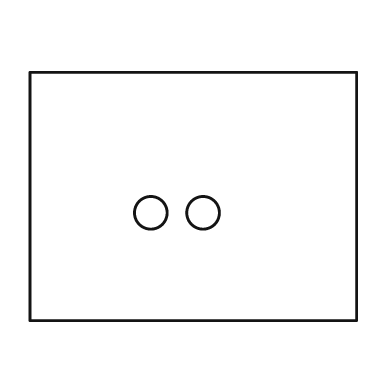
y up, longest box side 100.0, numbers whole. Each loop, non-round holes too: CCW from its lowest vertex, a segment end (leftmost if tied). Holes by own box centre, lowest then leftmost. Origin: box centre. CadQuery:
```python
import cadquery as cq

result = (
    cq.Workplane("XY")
    .moveTo(-50.0, -38.0)
    .lineTo(50.0, -38.0)
    .lineTo(50.0, 38.0)
    .lineTo(-50.0, 38.0)
    .close()
    .moveTo(-13.0, -5.0)
    .circle(5.0)
    .moveTo(3.0, -5.0)
    .circle(5.0)
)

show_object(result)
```